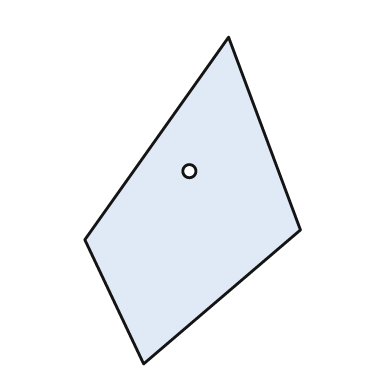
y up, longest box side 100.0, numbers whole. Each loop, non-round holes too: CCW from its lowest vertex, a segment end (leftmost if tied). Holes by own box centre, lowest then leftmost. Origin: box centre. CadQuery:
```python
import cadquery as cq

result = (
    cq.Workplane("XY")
    .moveTo(-15.0, -50.0)
    .lineTo(33.0, -9.0)
    .lineTo(11.0, 50.0)
    .lineTo(-33.0, -12.0)
    .close()
    .moveTo(-1.0, 9.0)
    .circle(2.0)
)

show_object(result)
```